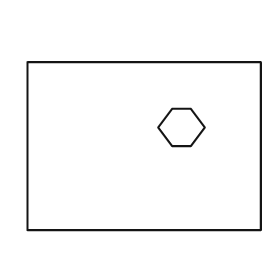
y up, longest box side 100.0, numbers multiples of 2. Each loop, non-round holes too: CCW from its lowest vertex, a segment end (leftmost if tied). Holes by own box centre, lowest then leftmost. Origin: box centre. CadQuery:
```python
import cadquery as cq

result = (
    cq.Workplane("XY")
    .moveTo(-50.0, -36.0)
    .lineTo(50.0, -36.0)
    .lineTo(50.0, 36.0)
    .lineTo(-50.0, 36.0)
    .close()
    .moveTo(12.0, 0.0)
    .lineTo(20.0, 0.0)
    .lineTo(26.0, 8.0)
    .lineTo(20.0, 16.0)
    .lineTo(12.0, 16.0)
    .lineTo(6.0, 8.0)
    .close()
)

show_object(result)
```